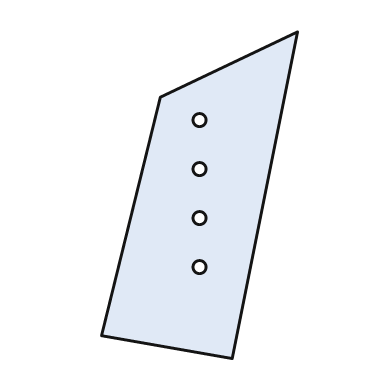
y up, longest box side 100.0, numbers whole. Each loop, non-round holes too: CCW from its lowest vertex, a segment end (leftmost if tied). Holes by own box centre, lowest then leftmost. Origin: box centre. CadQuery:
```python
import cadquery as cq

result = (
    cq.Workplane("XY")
    .moveTo(10.0, -50.0)
    .lineTo(30.0, 50.0)
    .lineTo(-12.0, 30.0)
    .lineTo(-30.0, -43.0)
    .close()
    .moveTo(0.0, -22.0)
    .circle(2.0)
    .moveTo(0.0, -7.0)
    .circle(2.0)
    .moveTo(0.0, 8.0)
    .circle(2.0)
    .moveTo(0.0, 23.0)
    .circle(2.0)
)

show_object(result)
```